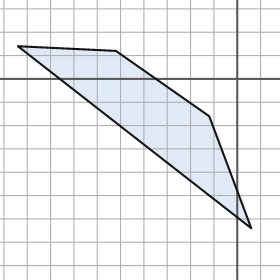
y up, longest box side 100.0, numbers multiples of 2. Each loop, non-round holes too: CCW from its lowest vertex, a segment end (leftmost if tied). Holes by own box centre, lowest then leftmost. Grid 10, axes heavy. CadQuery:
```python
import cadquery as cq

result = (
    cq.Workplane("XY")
    .moveTo(6.0, -64.0)
    .lineTo(-12.0, -16.0)
    .lineTo(-52.0, 12.0)
    .lineTo(-94.0, 14.0)
    .close()
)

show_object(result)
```